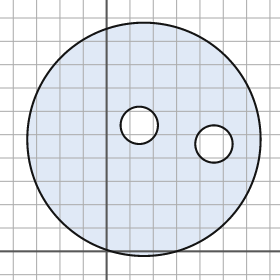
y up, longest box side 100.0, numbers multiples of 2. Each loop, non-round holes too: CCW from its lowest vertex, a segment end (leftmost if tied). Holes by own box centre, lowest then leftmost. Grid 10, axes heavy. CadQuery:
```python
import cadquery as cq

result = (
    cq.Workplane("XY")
    .moveTo(16.0, 48.0)
    .circle(50.0)
    .moveTo(46.0, 46.0)
    .circle(8.0)
    .moveTo(14.0, 54.0)
    .circle(8.0)
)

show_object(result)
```